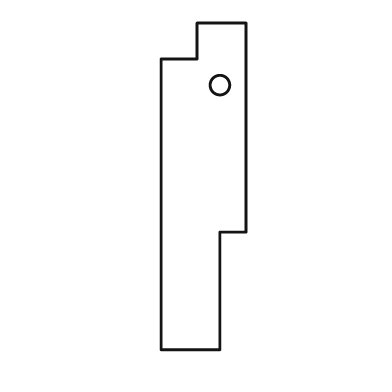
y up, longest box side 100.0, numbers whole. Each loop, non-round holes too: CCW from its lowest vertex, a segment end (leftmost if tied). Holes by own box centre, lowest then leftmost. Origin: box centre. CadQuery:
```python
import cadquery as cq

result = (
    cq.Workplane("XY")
    .moveTo(-13.0, -50.0)
    .lineTo(5.0, -50.0)
    .lineTo(5.0, -14.0)
    .lineTo(13.0, -14.0)
    .lineTo(13.0, 50.0)
    .lineTo(-2.0, 50.0)
    .lineTo(-2.0, 39.0)
    .lineTo(-13.0, 39.0)
    .close()
    .moveTo(5.0, 31.0)
    .circle(3.0)
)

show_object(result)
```